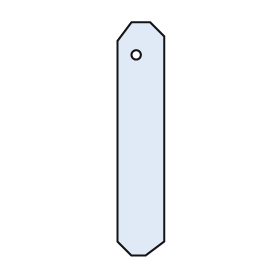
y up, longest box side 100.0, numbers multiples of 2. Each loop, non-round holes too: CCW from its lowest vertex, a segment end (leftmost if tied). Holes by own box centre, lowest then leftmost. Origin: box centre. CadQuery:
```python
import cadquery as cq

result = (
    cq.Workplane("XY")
    .moveTo(-4.0, -50.0)
    .lineTo(2.0, -50.0)
    .lineTo(10.0, -44.0)
    .lineTo(10.0, 44.0)
    .lineTo(4.0, 50.0)
    .lineTo(-4.0, 50.0)
    .lineTo(-10.0, 42.0)
    .lineTo(-10.0, -44.0)
    .close()
    .moveTo(-2.0, 36.0)
    .circle(2.0)
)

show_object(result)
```